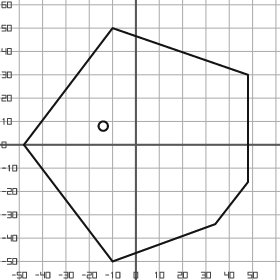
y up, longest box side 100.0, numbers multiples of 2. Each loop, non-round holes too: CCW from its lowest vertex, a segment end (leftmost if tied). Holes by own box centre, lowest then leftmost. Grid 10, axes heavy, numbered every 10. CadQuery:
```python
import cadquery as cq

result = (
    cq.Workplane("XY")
    .moveTo(-10.0, -50.0)
    .lineTo(34.0, -34.0)
    .lineTo(48.0, -16.0)
    .lineTo(48.0, 30.0)
    .lineTo(-10.0, 50.0)
    .lineTo(-48.0, 0.0)
    .close()
    .moveTo(-14.0, 8.0)
    .circle(2.0)
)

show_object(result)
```